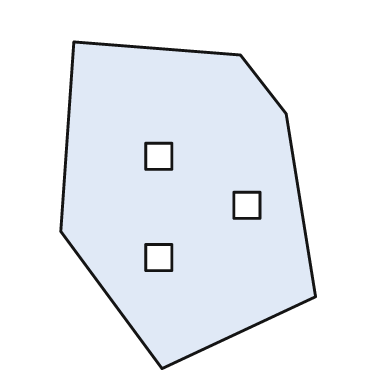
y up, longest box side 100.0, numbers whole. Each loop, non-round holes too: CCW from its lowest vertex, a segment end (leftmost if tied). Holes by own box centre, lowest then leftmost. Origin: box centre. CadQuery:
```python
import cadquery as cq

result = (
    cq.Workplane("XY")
    .moveTo(-8.0, -50.0)
    .lineTo(39.0, -28.0)
    .lineTo(30.0, 28.0)
    .lineTo(16.0, 46.0)
    .lineTo(-35.0, 50.0)
    .lineTo(-39.0, -8.0)
    .close()
    .moveTo(-13.0, -20.0)
    .lineTo(-5.0, -20.0)
    .lineTo(-5.0, -12.0)
    .lineTo(-13.0, -12.0)
    .close()
    .moveTo(14.0, -4.0)
    .lineTo(22.0, -4.0)
    .lineTo(22.0, 4.0)
    .lineTo(14.0, 4.0)
    .close()
    .moveTo(-13.0, 11.0)
    .lineTo(-5.0, 11.0)
    .lineTo(-5.0, 19.0)
    .lineTo(-13.0, 19.0)
    .close()
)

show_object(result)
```